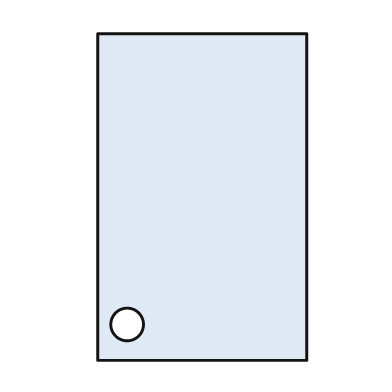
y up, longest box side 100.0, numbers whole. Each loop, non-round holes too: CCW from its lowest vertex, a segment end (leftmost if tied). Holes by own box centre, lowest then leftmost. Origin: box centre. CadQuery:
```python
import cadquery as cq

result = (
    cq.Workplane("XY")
    .moveTo(-32.0, -50.0)
    .lineTo(32.0, -50.0)
    .lineTo(32.0, 50.0)
    .lineTo(-32.0, 50.0)
    .close()
    .moveTo(-23.0, -39.0)
    .circle(5.0)
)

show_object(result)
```